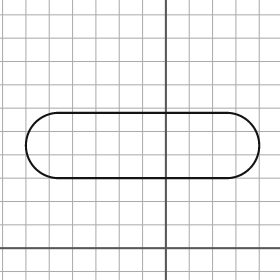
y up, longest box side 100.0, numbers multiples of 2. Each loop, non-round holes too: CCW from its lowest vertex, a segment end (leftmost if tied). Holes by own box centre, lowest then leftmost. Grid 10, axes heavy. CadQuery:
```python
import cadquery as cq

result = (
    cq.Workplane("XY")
    .moveTo(-46.0, 30.0)
    .lineTo(26.0, 30.0)
    .threePointArc((40.0, 44.0), (26.0, 58.0))
    .lineTo(-46.0, 58.0)
    .threePointArc((-60.0, 44.0), (-46.0, 30.0))
    .close()
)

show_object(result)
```